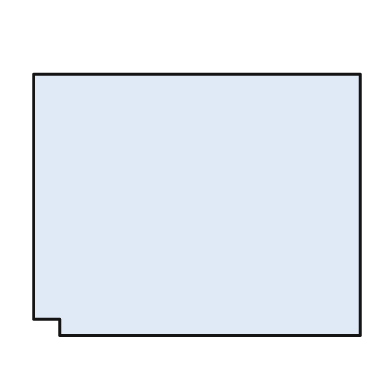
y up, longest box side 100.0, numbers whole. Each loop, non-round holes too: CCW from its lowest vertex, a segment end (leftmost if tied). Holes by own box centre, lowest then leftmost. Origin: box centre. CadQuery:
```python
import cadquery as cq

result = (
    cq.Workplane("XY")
    .moveTo(-42.0, -40.0)
    .lineTo(50.0, -40.0)
    .lineTo(50.0, 40.0)
    .lineTo(-50.0, 40.0)
    .lineTo(-50.0, -35.0)
    .lineTo(-42.0, -35.0)
    .close()
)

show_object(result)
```